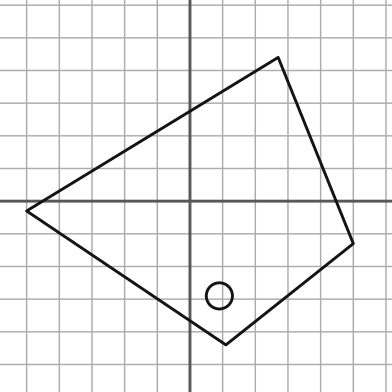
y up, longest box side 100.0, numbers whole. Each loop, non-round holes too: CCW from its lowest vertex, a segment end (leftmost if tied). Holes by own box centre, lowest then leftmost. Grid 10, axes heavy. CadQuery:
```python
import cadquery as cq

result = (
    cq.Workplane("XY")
    .moveTo(11.0, -44.0)
    .lineTo(50.0, -13.0)
    .lineTo(27.0, 44.0)
    .lineTo(-50.0, -3.0)
    .close()
    .moveTo(9.0, -29.0)
    .circle(4.0)
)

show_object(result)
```